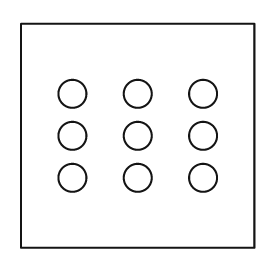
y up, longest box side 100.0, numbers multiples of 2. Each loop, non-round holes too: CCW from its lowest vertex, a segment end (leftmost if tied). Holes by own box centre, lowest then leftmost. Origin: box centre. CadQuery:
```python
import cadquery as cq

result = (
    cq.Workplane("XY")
    .moveTo(-50.0, -48.0)
    .lineTo(50.0, -48.0)
    .lineTo(50.0, 48.0)
    .lineTo(-50.0, 48.0)
    .close()
    .moveTo(-28.0, -18.0)
    .circle(6.0)
    .moveTo(0.0, -18.0)
    .circle(6.0)
    .moveTo(28.0, -18.0)
    .circle(6.0)
    .moveTo(-28.0, 0.0)
    .circle(6.0)
    .moveTo(0.0, 0.0)
    .circle(6.0)
    .moveTo(28.0, 0.0)
    .circle(6.0)
    .moveTo(-28.0, 18.0)
    .circle(6.0)
    .moveTo(0.0, 18.0)
    .circle(6.0)
    .moveTo(28.0, 18.0)
    .circle(6.0)
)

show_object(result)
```